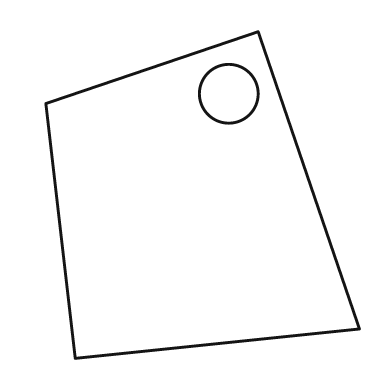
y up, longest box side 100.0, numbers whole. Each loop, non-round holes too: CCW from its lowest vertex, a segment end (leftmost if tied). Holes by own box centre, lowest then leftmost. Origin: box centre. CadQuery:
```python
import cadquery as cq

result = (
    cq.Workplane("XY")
    .moveTo(-39.0, -50.0)
    .lineTo(48.0, -41.0)
    .lineTo(17.0, 50.0)
    .lineTo(-48.0, 28.0)
    .close()
    .moveTo(8.0, 31.0)
    .circle(9.0)
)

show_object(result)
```